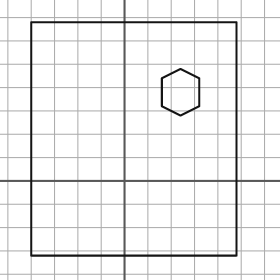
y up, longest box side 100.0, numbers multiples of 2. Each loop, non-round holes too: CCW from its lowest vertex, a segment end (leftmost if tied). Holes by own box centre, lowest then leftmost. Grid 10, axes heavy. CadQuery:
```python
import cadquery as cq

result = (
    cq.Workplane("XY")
    .moveTo(-40.0, -32.0)
    .lineTo(48.0, -32.0)
    .lineTo(48.0, 68.0)
    .lineTo(-40.0, 68.0)
    .close()
    .moveTo(24.0, 28.0)
    .lineTo(32.0, 32.0)
    .lineTo(32.0, 44.0)
    .lineTo(24.0, 48.0)
    .lineTo(16.0, 44.0)
    .lineTo(16.0, 32.0)
    .close()
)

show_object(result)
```